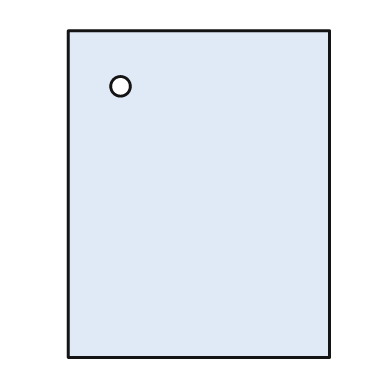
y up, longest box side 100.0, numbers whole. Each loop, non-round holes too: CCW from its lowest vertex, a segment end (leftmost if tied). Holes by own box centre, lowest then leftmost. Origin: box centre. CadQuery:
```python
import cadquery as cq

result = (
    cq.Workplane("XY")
    .moveTo(-40.0, -50.0)
    .lineTo(40.0, -50.0)
    .lineTo(40.0, 50.0)
    .lineTo(-40.0, 50.0)
    .close()
    .moveTo(-24.0, 33.0)
    .circle(3.0)
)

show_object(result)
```